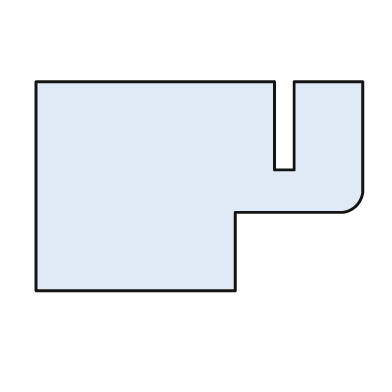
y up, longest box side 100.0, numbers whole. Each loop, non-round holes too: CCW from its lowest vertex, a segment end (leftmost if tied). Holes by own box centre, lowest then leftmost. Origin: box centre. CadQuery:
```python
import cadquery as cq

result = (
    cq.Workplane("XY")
    .moveTo(-50.0, -32.0)
    .lineTo(11.0, -32.0)
    .lineTo(11.0, -8.0)
    .lineTo(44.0, -8.0)
    .threePointArc((48.0, -6.0), (50.0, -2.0))
    .lineTo(50.0, 32.0)
    .lineTo(29.0, 32.0)
    .lineTo(29.0, 5.0)
    .lineTo(23.0, 5.0)
    .lineTo(23.0, 32.0)
    .lineTo(-50.0, 32.0)
    .close()
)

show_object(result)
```